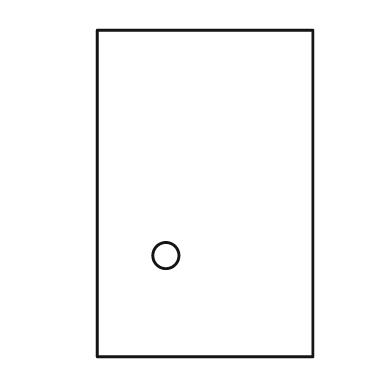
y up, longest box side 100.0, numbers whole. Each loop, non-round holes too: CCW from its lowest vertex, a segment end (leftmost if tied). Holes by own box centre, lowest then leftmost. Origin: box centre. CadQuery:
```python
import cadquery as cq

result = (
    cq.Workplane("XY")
    .moveTo(-33.0, -50.0)
    .lineTo(33.0, -50.0)
    .lineTo(33.0, 50.0)
    .lineTo(-33.0, 50.0)
    .close()
    .moveTo(-12.0, -19.0)
    .circle(4.0)
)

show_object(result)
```